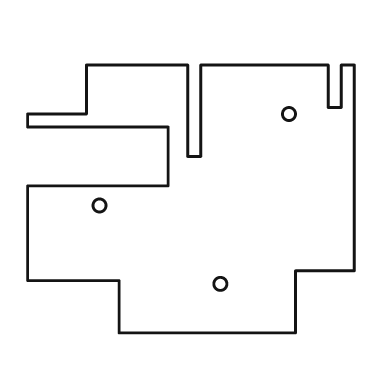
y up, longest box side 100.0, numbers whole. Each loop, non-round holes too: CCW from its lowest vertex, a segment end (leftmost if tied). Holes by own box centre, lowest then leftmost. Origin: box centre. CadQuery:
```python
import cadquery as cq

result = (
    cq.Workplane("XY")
    .moveTo(-22.0, -41.0)
    .lineTo(32.0, -41.0)
    .lineTo(32.0, -22.0)
    .lineTo(50.0, -22.0)
    .lineTo(50.0, 41.0)
    .lineTo(46.0, 41.0)
    .lineTo(46.0, 28.0)
    .lineTo(42.0, 28.0)
    .lineTo(42.0, 41.0)
    .lineTo(3.0, 41.0)
    .lineTo(3.0, 13.0)
    .lineTo(-1.0, 13.0)
    .lineTo(-1.0, 41.0)
    .lineTo(-32.0, 41.0)
    .lineTo(-32.0, 26.0)
    .lineTo(-50.0, 26.0)
    .lineTo(-50.0, 22.0)
    .lineTo(-7.0, 22.0)
    .lineTo(-7.0, 4.0)
    .lineTo(-50.0, 4.0)
    .lineTo(-50.0, -25.0)
    .lineTo(-22.0, -25.0)
    .close()
    .moveTo(9.0, -26.0)
    .circle(2.0)
    .moveTo(-28.0, -2.0)
    .circle(2.0)
    .moveTo(30.0, 26.0)
    .circle(2.0)
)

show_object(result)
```